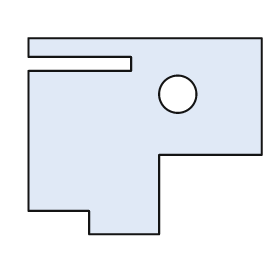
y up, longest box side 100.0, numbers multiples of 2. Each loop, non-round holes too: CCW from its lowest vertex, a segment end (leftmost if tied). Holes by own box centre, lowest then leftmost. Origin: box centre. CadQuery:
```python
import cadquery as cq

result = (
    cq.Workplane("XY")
    .moveTo(-24.0, -42.0)
    .lineTo(6.0, -42.0)
    .lineTo(6.0, -8.0)
    .lineTo(50.0, -8.0)
    .lineTo(50.0, 42.0)
    .lineTo(-50.0, 42.0)
    .lineTo(-50.0, 34.0)
    .lineTo(-6.0, 34.0)
    .lineTo(-6.0, 28.0)
    .lineTo(-50.0, 28.0)
    .lineTo(-50.0, -32.0)
    .lineTo(-24.0, -32.0)
    .close()
    .moveTo(14.0, 18.0)
    .circle(8.0)
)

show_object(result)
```